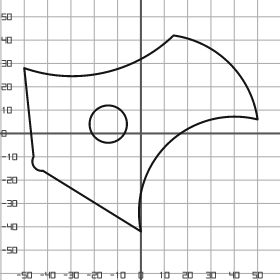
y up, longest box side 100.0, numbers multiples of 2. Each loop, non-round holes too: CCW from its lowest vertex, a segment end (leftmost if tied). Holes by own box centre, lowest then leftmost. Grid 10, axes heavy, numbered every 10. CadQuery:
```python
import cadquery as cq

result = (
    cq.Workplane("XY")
    .moveTo(0.0, -42.0)
    .threePointArc((12.0, -4.0), (50.0, 6.0))
    .threePointArc((38.0, 30.0), (14.0, 42.0))
    .threePointArc((-16.0, 26.0), (-50.0, 28.0))
    .lineTo(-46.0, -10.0)
    .threePointArc((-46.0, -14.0), (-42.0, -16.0))
    .close()
    .moveTo(-14.0, 4.0)
    .circle(8.0)
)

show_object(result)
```